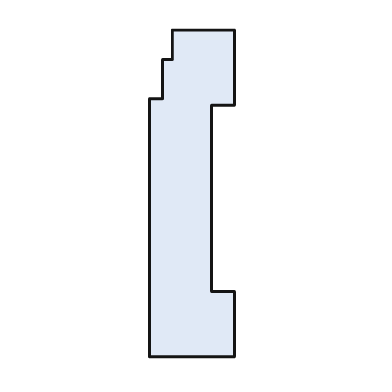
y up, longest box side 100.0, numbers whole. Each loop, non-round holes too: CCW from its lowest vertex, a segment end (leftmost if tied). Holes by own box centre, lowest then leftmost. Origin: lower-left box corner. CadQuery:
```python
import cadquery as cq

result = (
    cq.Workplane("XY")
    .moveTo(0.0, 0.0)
    .lineTo(26.0, 0.0)
    .lineTo(26.0, 20.0)
    .lineTo(19.0, 20.0)
    .lineTo(19.0, 77.0)
    .lineTo(26.0, 77.0)
    .lineTo(26.0, 100.0)
    .lineTo(7.0, 100.0)
    .lineTo(7.0, 91.0)
    .lineTo(4.0, 91.0)
    .lineTo(4.0, 79.0)
    .lineTo(0.0, 79.0)
    .close()
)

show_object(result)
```